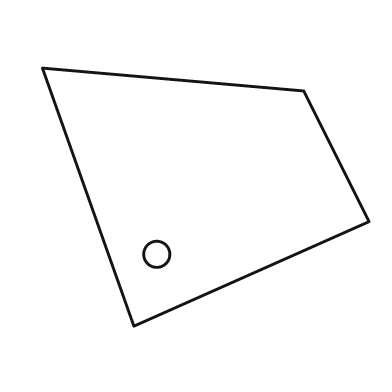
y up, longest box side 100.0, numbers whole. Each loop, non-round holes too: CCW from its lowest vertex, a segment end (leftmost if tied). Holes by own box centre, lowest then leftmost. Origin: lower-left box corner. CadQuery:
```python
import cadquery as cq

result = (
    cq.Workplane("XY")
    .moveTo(28.0, 0.0)
    .lineTo(100.0, 32.0)
    .lineTo(80.0, 72.0)
    .lineTo(0.0, 79.0)
    .close()
    .moveTo(35.0, 22.0)
    .circle(4.0)
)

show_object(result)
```